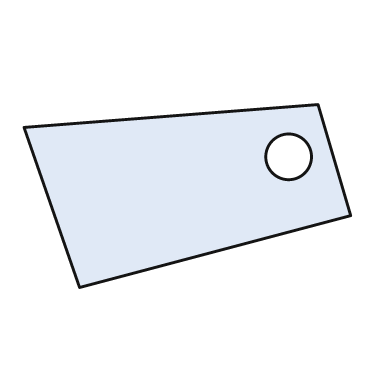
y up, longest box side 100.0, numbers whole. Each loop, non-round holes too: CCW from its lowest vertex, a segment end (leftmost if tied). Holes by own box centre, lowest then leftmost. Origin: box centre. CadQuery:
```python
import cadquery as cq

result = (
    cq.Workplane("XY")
    .moveTo(-33.0, -28.0)
    .lineTo(50.0, -6.0)
    .lineTo(40.0, 28.0)
    .lineTo(-50.0, 21.0)
    .close()
    .moveTo(31.0, 12.0)
    .circle(7.0)
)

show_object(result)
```